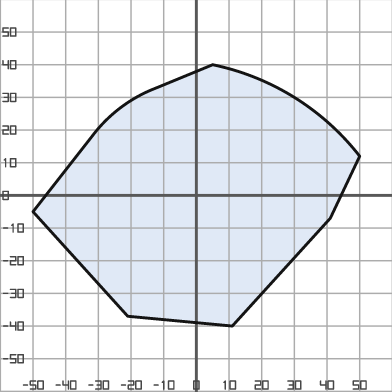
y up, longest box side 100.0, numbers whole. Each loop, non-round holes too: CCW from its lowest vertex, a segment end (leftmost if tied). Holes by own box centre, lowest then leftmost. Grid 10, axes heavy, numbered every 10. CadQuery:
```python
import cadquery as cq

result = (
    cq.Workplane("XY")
    .moveTo(11.0, -40.0)
    .lineTo(41.0, -7.0)
    .lineTo(50.0, 12.0)
    .threePointArc((30.0, 30.0), (5.0, 40.0))
    .lineTo(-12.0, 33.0)
    .threePointArc((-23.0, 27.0), (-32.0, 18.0))
    .lineTo(-50.0, -5.0)
    .lineTo(-21.0, -37.0)
    .close()
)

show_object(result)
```